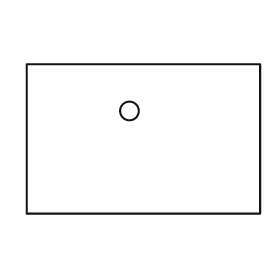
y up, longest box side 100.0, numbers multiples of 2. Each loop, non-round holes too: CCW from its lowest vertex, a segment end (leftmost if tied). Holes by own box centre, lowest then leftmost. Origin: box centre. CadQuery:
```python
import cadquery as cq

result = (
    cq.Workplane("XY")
    .moveTo(-50.0, -32.0)
    .lineTo(50.0, -32.0)
    .lineTo(50.0, 32.0)
    .lineTo(-50.0, 32.0)
    .close()
    .moveTo(-6.0, 12.0)
    .circle(4.0)
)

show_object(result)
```